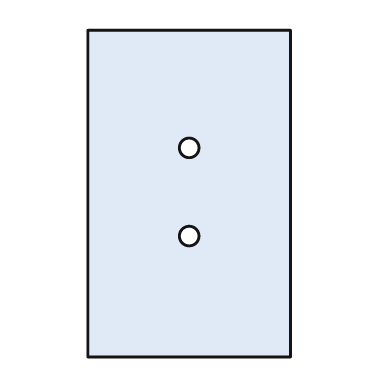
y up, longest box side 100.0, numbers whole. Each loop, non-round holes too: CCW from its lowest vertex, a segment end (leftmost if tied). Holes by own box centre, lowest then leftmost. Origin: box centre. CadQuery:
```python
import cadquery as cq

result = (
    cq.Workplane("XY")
    .moveTo(-31.0, -50.0)
    .lineTo(31.0, -50.0)
    .lineTo(31.0, 50.0)
    .lineTo(-31.0, 50.0)
    .close()
    .moveTo(0.0, -13.0)
    .circle(3.0)
    .moveTo(0.0, 14.0)
    .circle(3.0)
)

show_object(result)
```